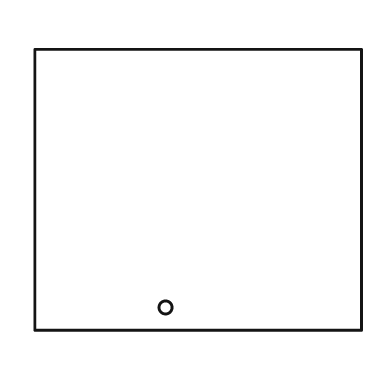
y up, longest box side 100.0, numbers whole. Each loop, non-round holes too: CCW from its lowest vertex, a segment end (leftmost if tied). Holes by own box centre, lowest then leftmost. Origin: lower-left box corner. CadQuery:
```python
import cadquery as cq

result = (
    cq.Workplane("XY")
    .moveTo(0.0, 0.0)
    .lineTo(100.0, 0.0)
    .lineTo(100.0, 86.0)
    .lineTo(0.0, 86.0)
    .close()
    .moveTo(40.0, 7.0)
    .circle(2.0)
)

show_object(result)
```